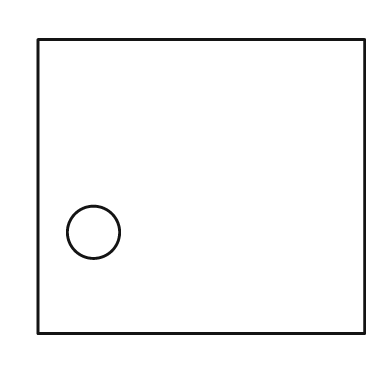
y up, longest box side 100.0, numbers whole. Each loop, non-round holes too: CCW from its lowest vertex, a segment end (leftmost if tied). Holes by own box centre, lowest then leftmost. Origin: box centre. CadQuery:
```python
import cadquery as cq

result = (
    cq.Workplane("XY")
    .moveTo(-50.0, -45.0)
    .lineTo(50.0, -45.0)
    .lineTo(50.0, 45.0)
    .lineTo(-50.0, 45.0)
    .close()
    .moveTo(-33.0, -14.0)
    .circle(8.0)
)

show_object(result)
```